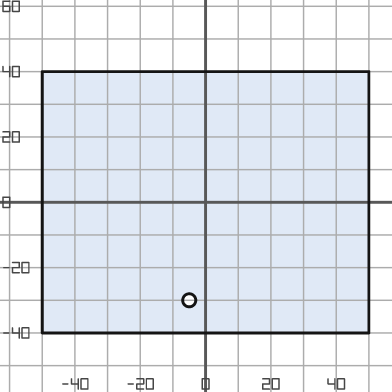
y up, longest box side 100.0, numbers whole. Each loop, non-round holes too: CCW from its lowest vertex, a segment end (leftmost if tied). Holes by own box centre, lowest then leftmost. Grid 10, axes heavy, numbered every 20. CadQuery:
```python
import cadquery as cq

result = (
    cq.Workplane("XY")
    .moveTo(-50.0, -40.0)
    .lineTo(50.0, -40.0)
    .lineTo(50.0, 40.0)
    .lineTo(-50.0, 40.0)
    .close()
    .moveTo(-5.0, -30.0)
    .circle(2.0)
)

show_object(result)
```